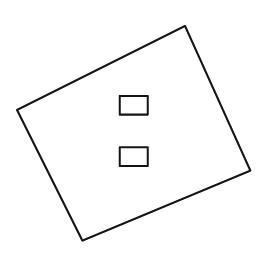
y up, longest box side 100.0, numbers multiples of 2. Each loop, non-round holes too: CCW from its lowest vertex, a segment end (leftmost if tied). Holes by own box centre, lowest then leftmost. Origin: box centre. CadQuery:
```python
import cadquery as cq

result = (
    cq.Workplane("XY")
    .moveTo(-22.0, -46.0)
    .lineTo(50.0, -16.0)
    .lineTo(22.0, 46.0)
    .lineTo(-50.0, 10.0)
    .close()
    .moveTo(-6.0, -14.0)
    .lineTo(6.0, -14.0)
    .lineTo(6.0, -6.0)
    .lineTo(-6.0, -6.0)
    .close()
    .moveTo(-6.0, 8.0)
    .lineTo(6.0, 8.0)
    .lineTo(6.0, 16.0)
    .lineTo(-6.0, 16.0)
    .close()
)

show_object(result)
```